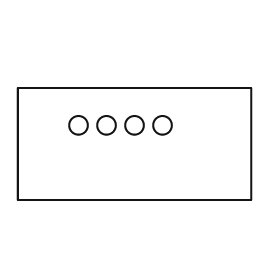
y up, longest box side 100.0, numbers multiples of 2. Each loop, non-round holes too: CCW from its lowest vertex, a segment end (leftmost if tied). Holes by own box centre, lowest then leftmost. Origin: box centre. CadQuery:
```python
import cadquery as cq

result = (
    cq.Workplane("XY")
    .moveTo(-50.0, -24.0)
    .lineTo(50.0, -24.0)
    .lineTo(50.0, 24.0)
    .lineTo(-50.0, 24.0)
    .close()
    .moveTo(-24.0, 8.0)
    .circle(4.0)
    .moveTo(-12.0, 8.0)
    .circle(4.0)
    .moveTo(0.0, 8.0)
    .circle(4.0)
    .moveTo(12.0, 8.0)
    .circle(4.0)
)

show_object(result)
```